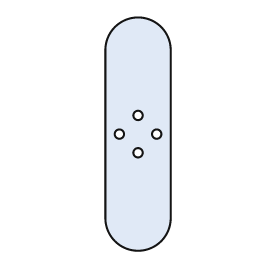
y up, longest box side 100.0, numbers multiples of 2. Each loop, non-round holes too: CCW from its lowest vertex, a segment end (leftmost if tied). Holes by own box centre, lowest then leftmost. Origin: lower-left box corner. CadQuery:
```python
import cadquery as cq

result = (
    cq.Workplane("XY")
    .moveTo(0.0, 14.0)
    .threePointArc((14.0, 0.0), (28.0, 14.0))
    .lineTo(28.0, 86.0)
    .threePointArc((14.0, 100.0), (0.0, 86.0))
    .close()
    .moveTo(14.0, 42.0)
    .circle(2.0)
    .moveTo(6.0, 50.0)
    .circle(2.0)
    .moveTo(22.0, 50.0)
    .circle(2.0)
    .moveTo(14.0, 58.0)
    .circle(2.0)
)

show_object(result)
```